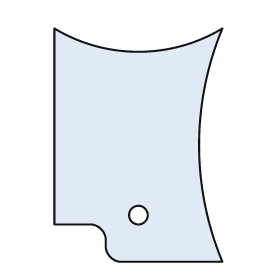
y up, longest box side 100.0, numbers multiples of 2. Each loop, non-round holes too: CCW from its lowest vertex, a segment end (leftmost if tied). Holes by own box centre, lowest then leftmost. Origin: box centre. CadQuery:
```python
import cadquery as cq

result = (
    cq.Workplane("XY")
    .moveTo(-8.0, -50.0)
    .lineTo(36.0, -50.0)
    .threePointArc((26.0, 0.0), (36.0, 50.0))
    .threePointArc((0.0, 40.0), (-36.0, 50.0))
    .lineTo(-36.0, -34.0)
    .lineTo(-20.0, -34.0)
    .threePointArc((-16.0, -36.0), (-14.0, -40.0))
    .lineTo(-14.0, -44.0)
    .threePointArc((-12.0, -48.0), (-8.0, -50.0))
    .close()
    .moveTo(0.0, -30.0)
    .circle(4.0)
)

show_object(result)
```